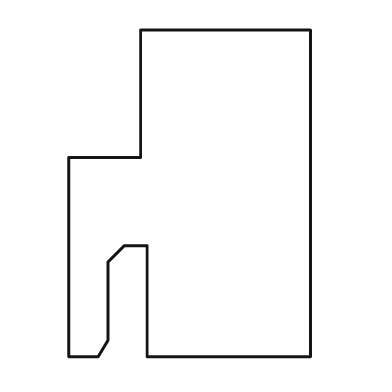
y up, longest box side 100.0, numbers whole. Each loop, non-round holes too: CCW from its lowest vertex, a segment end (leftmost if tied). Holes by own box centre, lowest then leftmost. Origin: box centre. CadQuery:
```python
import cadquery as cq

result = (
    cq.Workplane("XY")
    .moveTo(-37.0, -50.0)
    .lineTo(-28.0, -50.0)
    .lineTo(-25.0, -45.0)
    .lineTo(-25.0, -21.0)
    .lineTo(-20.0, -16.0)
    .lineTo(-13.0, -16.0)
    .lineTo(-13.0, -50.0)
    .lineTo(37.0, -50.0)
    .lineTo(37.0, 50.0)
    .lineTo(-15.0, 50.0)
    .lineTo(-15.0, 11.0)
    .lineTo(-37.0, 11.0)
    .close()
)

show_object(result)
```